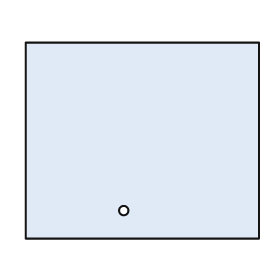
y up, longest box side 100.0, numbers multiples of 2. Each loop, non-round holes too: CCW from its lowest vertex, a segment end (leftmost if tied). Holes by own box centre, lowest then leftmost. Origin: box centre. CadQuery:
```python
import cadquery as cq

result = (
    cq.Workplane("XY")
    .moveTo(-50.0, -42.0)
    .lineTo(50.0, -42.0)
    .lineTo(50.0, 42.0)
    .lineTo(-50.0, 42.0)
    .close()
    .moveTo(-8.0, -30.0)
    .circle(2.0)
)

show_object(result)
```